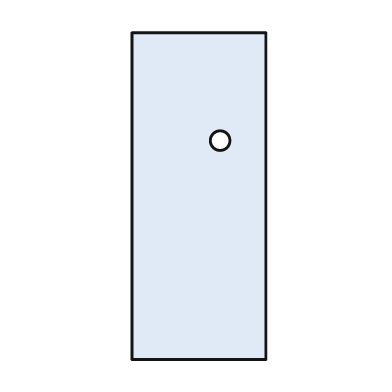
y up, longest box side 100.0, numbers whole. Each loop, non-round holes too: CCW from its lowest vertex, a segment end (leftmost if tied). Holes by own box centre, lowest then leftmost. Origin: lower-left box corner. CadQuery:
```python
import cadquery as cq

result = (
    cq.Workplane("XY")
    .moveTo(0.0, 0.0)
    .lineTo(41.0, 0.0)
    .lineTo(41.0, 100.0)
    .lineTo(0.0, 100.0)
    .close()
    .moveTo(27.0, 67.0)
    .circle(3.0)
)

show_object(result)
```